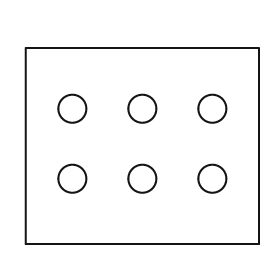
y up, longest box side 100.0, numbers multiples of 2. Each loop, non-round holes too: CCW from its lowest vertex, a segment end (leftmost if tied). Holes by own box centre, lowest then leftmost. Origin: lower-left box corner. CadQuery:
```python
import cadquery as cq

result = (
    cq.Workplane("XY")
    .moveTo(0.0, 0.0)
    .lineTo(100.0, 0.0)
    .lineTo(100.0, 84.0)
    .lineTo(0.0, 84.0)
    .close()
    .moveTo(20.0, 28.0)
    .circle(6.0)
    .moveTo(50.0, 28.0)
    .circle(6.0)
    .moveTo(80.0, 28.0)
    .circle(6.0)
    .moveTo(20.0, 58.0)
    .circle(6.0)
    .moveTo(50.0, 58.0)
    .circle(6.0)
    .moveTo(80.0, 58.0)
    .circle(6.0)
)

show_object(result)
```